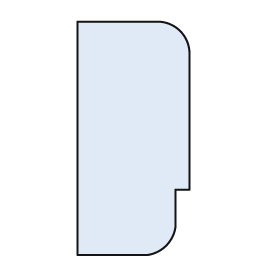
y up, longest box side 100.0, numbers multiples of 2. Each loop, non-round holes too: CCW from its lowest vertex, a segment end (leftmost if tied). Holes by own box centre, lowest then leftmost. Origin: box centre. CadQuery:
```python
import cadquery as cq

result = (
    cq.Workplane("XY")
    .moveTo(-24.0, -50.0)
    .lineTo(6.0, -50.0)
    .threePointArc((14.0, -46.0), (18.0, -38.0))
    .lineTo(18.0, -22.0)
    .lineTo(24.0, -22.0)
    .lineTo(24.0, 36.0)
    .threePointArc((20.0, 46.0), (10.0, 50.0))
    .lineTo(-24.0, 50.0)
    .close()
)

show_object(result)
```